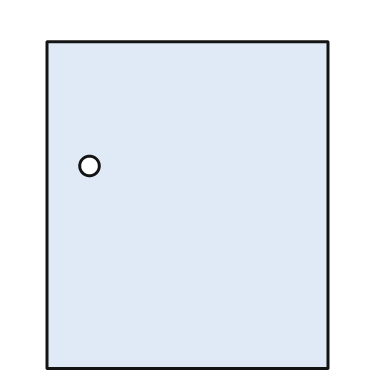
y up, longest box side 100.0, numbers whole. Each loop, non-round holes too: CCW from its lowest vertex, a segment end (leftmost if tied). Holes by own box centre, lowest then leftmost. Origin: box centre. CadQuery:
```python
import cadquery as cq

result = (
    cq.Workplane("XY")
    .moveTo(-43.0, -50.0)
    .lineTo(43.0, -50.0)
    .lineTo(43.0, 50.0)
    .lineTo(-43.0, 50.0)
    .close()
    .moveTo(-30.0, 12.0)
    .circle(3.0)
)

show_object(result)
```